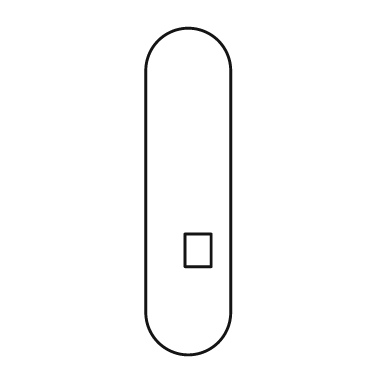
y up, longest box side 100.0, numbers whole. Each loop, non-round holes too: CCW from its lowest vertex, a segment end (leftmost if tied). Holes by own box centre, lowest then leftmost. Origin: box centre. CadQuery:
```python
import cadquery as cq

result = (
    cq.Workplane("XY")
    .moveTo(-13.0, -37.0)
    .threePointArc((0.0, -50.0), (13.0, -37.0))
    .lineTo(13.0, 37.0)
    .threePointArc((0.0, 50.0), (-13.0, 37.0))
    .close()
    .moveTo(-1.0, -23.0)
    .lineTo(7.0, -23.0)
    .lineTo(7.0, -13.0)
    .lineTo(-1.0, -13.0)
    .close()
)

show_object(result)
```